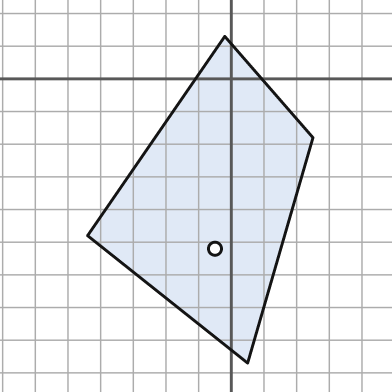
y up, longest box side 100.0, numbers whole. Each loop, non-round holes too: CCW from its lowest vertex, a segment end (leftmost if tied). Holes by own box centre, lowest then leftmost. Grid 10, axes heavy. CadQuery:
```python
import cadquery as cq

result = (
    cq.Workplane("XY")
    .moveTo(5.0, -87.0)
    .lineTo(25.0, -18.0)
    .lineTo(-2.0, 13.0)
    .lineTo(-44.0, -48.0)
    .close()
    .moveTo(-5.0, -52.0)
    .circle(2.0)
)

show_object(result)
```